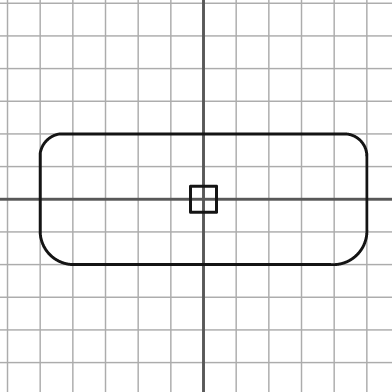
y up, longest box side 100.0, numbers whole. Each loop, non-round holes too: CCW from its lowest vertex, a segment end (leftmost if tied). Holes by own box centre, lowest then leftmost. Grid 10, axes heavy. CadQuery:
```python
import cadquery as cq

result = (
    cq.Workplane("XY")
    .moveTo(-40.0, -20.0)
    .lineTo(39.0, -20.0)
    .threePointArc((47.0, -17.0), (50.0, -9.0))
    .lineTo(50.0, 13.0)
    .threePointArc((48.0, 18.0), (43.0, 20.0))
    .lineTo(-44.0, 20.0)
    .threePointArc((-48.0, 18.0), (-50.0, 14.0))
    .lineTo(-50.0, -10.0)
    .threePointArc((-47.0, -17.0), (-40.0, -20.0))
    .close()
    .moveTo(-4.0, -4.0)
    .lineTo(4.0, -4.0)
    .lineTo(4.0, 4.0)
    .lineTo(-4.0, 4.0)
    .close()
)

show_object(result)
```